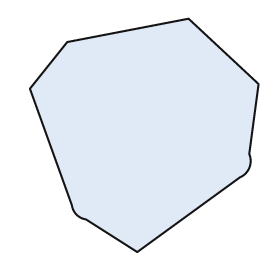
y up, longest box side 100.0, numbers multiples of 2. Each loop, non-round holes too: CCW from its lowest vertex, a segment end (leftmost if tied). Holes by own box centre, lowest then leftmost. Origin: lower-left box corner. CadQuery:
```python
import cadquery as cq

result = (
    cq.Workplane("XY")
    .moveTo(46.0, 0.0)
    .lineTo(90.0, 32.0)
    .threePointArc((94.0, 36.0), (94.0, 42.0))
    .lineTo(98.0, 72.0)
    .lineTo(68.0, 100.0)
    .lineTo(16.0, 90.0)
    .lineTo(0.0, 70.0)
    .lineTo(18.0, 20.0)
    .threePointArc((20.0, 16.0), (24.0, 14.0))
    .close()
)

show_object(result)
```